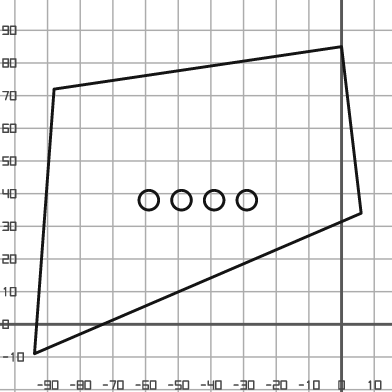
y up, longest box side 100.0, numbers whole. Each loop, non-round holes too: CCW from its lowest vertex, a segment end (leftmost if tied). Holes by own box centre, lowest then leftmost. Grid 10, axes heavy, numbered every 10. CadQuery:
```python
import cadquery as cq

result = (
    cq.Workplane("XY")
    .moveTo(-94.0, -9.0)
    .lineTo(6.0, 34.0)
    .lineTo(0.0, 85.0)
    .lineTo(-88.0, 72.0)
    .close()
    .moveTo(-59.0, 38.0)
    .circle(3.0)
    .moveTo(-49.0, 38.0)
    .circle(3.0)
    .moveTo(-39.0, 38.0)
    .circle(3.0)
    .moveTo(-29.0, 38.0)
    .circle(3.0)
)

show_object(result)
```